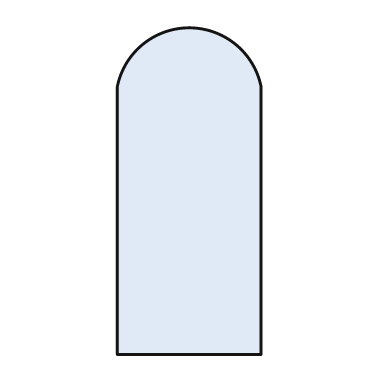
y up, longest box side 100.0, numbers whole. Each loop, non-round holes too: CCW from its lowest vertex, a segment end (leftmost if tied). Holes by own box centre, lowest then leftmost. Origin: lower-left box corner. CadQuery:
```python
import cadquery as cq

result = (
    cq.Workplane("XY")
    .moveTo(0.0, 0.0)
    .lineTo(44.0, 0.0)
    .lineTo(44.0, 82.0)
    .threePointArc((22.0, 100.0), (0.0, 82.0))
    .close()
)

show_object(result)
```